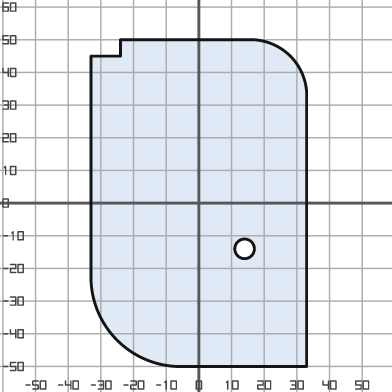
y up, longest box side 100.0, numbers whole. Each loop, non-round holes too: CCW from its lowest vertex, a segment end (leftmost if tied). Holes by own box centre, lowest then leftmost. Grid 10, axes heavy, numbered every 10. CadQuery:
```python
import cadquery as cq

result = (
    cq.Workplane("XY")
    .moveTo(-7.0, -50.0)
    .lineTo(33.0, -50.0)
    .lineTo(33.0, 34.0)
    .threePointArc((28.0, 45.0), (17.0, 50.0))
    .lineTo(-24.0, 50.0)
    .lineTo(-24.0, 45.0)
    .lineTo(-33.0, 45.0)
    .lineTo(-33.0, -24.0)
    .threePointArc((-25.0, -42.0), (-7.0, -50.0))
    .close()
    .moveTo(14.0, -14.0)
    .circle(3.0)
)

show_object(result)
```